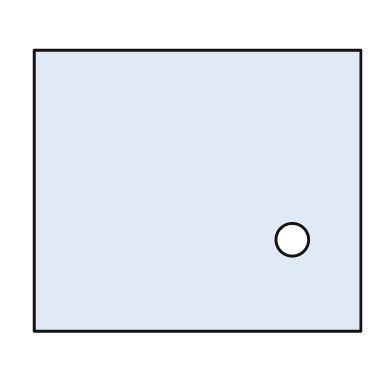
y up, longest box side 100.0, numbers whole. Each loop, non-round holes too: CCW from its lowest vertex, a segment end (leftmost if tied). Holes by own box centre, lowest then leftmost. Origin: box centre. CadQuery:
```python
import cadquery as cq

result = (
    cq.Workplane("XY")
    .moveTo(-50.0, -43.0)
    .lineTo(50.0, -43.0)
    .lineTo(50.0, 43.0)
    .lineTo(-50.0, 43.0)
    .close()
    .moveTo(29.0, -15.0)
    .circle(5.0)
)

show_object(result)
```